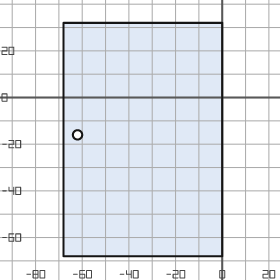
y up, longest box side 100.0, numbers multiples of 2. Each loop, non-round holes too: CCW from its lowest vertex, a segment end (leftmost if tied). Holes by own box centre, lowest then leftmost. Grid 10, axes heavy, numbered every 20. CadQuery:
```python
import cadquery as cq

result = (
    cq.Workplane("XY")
    .moveTo(-68.0, -68.0)
    .lineTo(0.0, -68.0)
    .lineTo(0.0, 32.0)
    .lineTo(-68.0, 32.0)
    .close()
    .moveTo(-62.0, -16.0)
    .circle(2.0)
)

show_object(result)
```